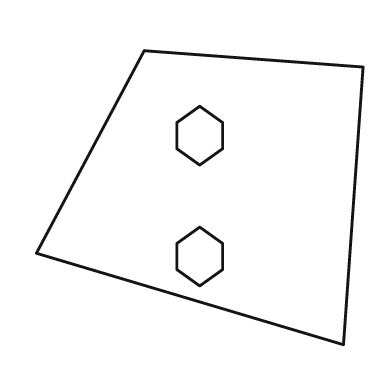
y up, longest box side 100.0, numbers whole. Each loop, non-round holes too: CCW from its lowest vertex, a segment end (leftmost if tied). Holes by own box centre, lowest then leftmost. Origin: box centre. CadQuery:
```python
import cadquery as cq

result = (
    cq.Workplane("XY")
    .moveTo(44.0, -45.0)
    .lineTo(50.0, 40.0)
    .lineTo(-17.0, 45.0)
    .lineTo(-50.0, -17.0)
    .close()
    .moveTo(0.0, -27.0)
    .lineTo(7.0, -22.0)
    .lineTo(7.0, -14.0)
    .lineTo(0.0, -9.0)
    .lineTo(-7.0, -14.0)
    .lineTo(-7.0, -22.0)
    .close()
    .moveTo(0.0, 10.0)
    .lineTo(7.0, 15.0)
    .lineTo(7.0, 23.0)
    .lineTo(0.0, 28.0)
    .lineTo(-7.0, 23.0)
    .lineTo(-7.0, 15.0)
    .close()
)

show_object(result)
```